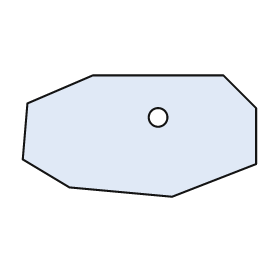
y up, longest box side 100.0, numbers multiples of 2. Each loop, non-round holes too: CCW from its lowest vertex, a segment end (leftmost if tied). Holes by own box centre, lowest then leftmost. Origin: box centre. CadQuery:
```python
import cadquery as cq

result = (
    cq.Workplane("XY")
    .moveTo(14.0, -26.0)
    .lineTo(50.0, -12.0)
    .lineTo(50.0, 12.0)
    .lineTo(36.0, 26.0)
    .lineTo(-20.0, 26.0)
    .lineTo(-48.0, 14.0)
    .lineTo(-50.0, -10.0)
    .lineTo(-30.0, -22.0)
    .close()
    .moveTo(8.0, 8.0)
    .circle(4.0)
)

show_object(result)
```